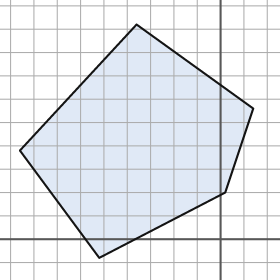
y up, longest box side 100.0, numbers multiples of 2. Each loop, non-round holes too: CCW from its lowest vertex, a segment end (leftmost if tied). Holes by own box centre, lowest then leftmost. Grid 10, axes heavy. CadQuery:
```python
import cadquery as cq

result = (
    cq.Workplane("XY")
    .moveTo(-52.0, -8.0)
    .lineTo(2.0, 20.0)
    .lineTo(14.0, 56.0)
    .lineTo(-36.0, 92.0)
    .lineTo(-86.0, 38.0)
    .close()
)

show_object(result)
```